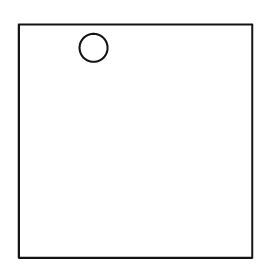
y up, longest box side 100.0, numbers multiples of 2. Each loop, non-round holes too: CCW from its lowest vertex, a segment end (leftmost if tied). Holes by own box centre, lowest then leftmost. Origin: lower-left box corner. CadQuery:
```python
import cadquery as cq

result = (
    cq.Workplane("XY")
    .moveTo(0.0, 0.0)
    .lineTo(100.0, 0.0)
    .lineTo(100.0, 100.0)
    .lineTo(0.0, 100.0)
    .close()
    .moveTo(32.0, 90.0)
    .circle(6.0)
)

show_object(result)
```